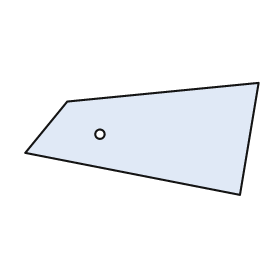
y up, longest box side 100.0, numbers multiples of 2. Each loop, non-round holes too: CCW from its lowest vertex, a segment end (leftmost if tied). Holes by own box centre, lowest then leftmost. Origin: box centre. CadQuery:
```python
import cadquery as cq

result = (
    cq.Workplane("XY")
    .moveTo(42.0, -24.0)
    .lineTo(50.0, 24.0)
    .lineTo(-32.0, 16.0)
    .lineTo(-50.0, -6.0)
    .close()
    .moveTo(-18.0, 2.0)
    .circle(2.0)
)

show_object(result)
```